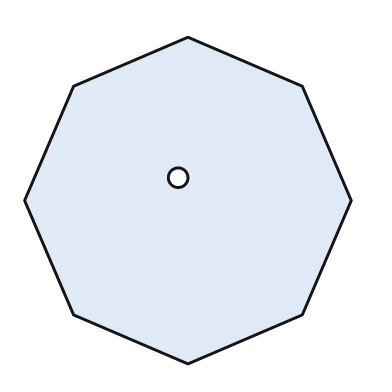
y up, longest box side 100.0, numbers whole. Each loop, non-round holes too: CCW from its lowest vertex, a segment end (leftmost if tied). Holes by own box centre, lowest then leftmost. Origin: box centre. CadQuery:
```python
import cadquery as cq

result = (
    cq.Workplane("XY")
    .moveTo(0.0, -50.0)
    .lineTo(35.0, -35.0)
    .lineTo(50.0, 0.0)
    .lineTo(35.0, 35.0)
    .lineTo(0.0, 50.0)
    .lineTo(-35.0, 35.0)
    .lineTo(-50.0, 0.0)
    .lineTo(-35.0, -35.0)
    .close()
    .moveTo(-3.0, 7.0)
    .circle(3.0)
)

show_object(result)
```